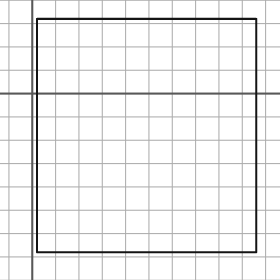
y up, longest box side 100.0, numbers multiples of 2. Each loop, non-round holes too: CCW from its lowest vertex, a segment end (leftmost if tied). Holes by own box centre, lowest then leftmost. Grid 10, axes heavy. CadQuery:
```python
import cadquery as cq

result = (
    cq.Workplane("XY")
    .moveTo(2.0, -68.0)
    .lineTo(96.0, -68.0)
    .lineTo(96.0, 32.0)
    .lineTo(2.0, 32.0)
    .close()
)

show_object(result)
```